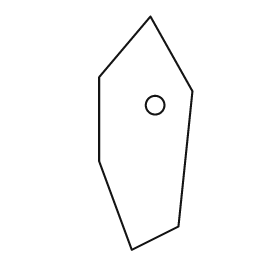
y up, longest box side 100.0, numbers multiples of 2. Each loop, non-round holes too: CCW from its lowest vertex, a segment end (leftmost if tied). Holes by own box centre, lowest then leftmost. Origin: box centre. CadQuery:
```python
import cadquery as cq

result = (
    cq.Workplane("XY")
    .moveTo(-6.0, -50.0)
    .lineTo(14.0, -40.0)
    .lineTo(20.0, 18.0)
    .lineTo(2.0, 50.0)
    .lineTo(-20.0, 24.0)
    .lineTo(-20.0, -12.0)
    .close()
    .moveTo(4.0, 12.0)
    .circle(4.0)
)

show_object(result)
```